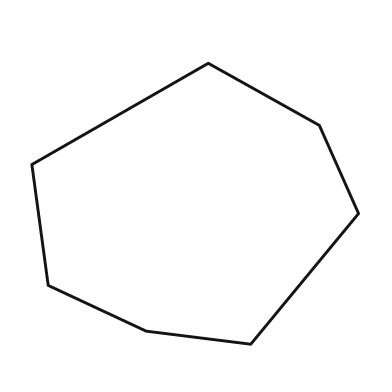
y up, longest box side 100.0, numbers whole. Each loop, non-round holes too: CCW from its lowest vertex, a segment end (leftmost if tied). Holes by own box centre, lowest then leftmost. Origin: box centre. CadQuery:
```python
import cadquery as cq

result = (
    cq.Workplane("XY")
    .moveTo(17.0, -43.0)
    .lineTo(50.0, -3.0)
    .lineTo(38.0, 24.0)
    .lineTo(4.0, 43.0)
    .lineTo(-50.0, 12.0)
    .lineTo(-45.0, -25.0)
    .lineTo(-15.0, -39.0)
    .close()
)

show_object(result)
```